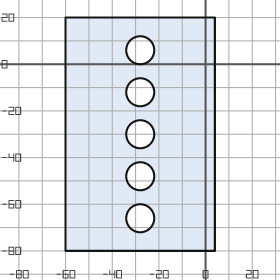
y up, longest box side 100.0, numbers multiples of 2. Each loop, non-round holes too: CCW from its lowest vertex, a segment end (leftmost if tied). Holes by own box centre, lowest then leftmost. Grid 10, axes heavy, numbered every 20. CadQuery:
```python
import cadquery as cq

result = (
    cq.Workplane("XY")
    .moveTo(-60.0, -80.0)
    .lineTo(4.0, -80.0)
    .lineTo(4.0, 20.0)
    .lineTo(-60.0, 20.0)
    .close()
    .moveTo(-28.0, -66.0)
    .circle(6.0)
    .moveTo(-28.0, -48.0)
    .circle(6.0)
    .moveTo(-28.0, -30.0)
    .circle(6.0)
    .moveTo(-28.0, -12.0)
    .circle(6.0)
    .moveTo(-28.0, 6.0)
    .circle(6.0)
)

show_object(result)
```